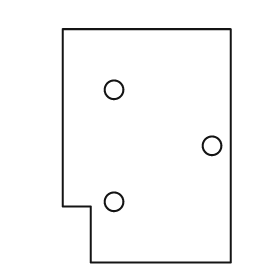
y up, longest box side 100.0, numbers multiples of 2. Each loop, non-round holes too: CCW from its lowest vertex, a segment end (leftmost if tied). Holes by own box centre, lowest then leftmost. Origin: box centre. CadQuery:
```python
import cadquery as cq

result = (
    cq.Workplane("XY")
    .moveTo(-24.0, -50.0)
    .lineTo(36.0, -50.0)
    .lineTo(36.0, 50.0)
    .lineTo(-36.0, 50.0)
    .lineTo(-36.0, -26.0)
    .lineTo(-24.0, -26.0)
    .close()
    .moveTo(-14.0, -24.0)
    .circle(4.0)
    .moveTo(28.0, 0.0)
    .circle(4.0)
    .moveTo(-14.0, 24.0)
    .circle(4.0)
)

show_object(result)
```